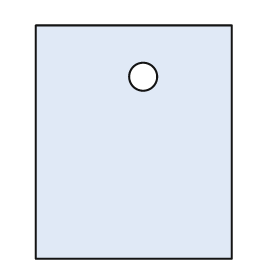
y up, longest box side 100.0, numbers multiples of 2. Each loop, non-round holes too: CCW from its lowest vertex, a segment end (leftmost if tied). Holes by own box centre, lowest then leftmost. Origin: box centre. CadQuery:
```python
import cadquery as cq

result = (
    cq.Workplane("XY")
    .moveTo(-42.0, -50.0)
    .lineTo(42.0, -50.0)
    .lineTo(42.0, 50.0)
    .lineTo(-42.0, 50.0)
    .close()
    .moveTo(4.0, 28.0)
    .circle(6.0)
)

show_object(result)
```